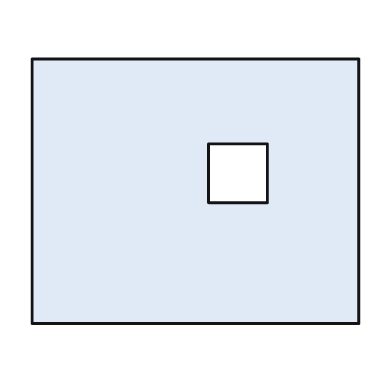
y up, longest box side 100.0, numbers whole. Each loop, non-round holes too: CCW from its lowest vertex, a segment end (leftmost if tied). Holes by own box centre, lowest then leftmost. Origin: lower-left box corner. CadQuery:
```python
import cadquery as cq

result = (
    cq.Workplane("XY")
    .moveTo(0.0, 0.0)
    .lineTo(100.0, 0.0)
    .lineTo(100.0, 81.0)
    .lineTo(0.0, 81.0)
    .close()
    .moveTo(54.0, 37.0)
    .lineTo(72.0, 37.0)
    .lineTo(72.0, 55.0)
    .lineTo(54.0, 55.0)
    .close()
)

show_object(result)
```